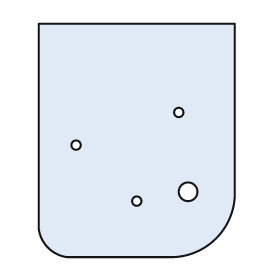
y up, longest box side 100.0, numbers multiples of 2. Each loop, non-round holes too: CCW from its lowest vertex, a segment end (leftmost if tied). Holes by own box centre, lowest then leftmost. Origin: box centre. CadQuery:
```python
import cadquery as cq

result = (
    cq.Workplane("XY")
    .moveTo(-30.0, -50.0)
    .lineTo(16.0, -50.0)
    .threePointArc((34.0, -42.0), (42.0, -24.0))
    .lineTo(42.0, 50.0)
    .lineTo(-42.0, 50.0)
    .lineTo(-42.0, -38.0)
    .threePointArc((-38.0, -46.0), (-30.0, -50.0))
    .close()
    .moveTo(0.0, -26.0)
    .circle(2.0)
    .moveTo(22.0, -22.0)
    .circle(4.0)
    .moveTo(-26.0, -2.0)
    .circle(2.0)
    .moveTo(18.0, 12.0)
    .circle(2.0)
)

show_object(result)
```